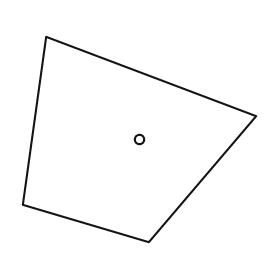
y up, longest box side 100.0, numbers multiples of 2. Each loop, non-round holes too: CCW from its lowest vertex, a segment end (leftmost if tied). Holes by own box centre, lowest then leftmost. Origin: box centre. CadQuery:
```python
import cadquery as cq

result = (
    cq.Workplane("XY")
    .moveTo(4.0, -44.0)
    .lineTo(50.0, 10.0)
    .lineTo(-40.0, 44.0)
    .lineTo(-50.0, -28.0)
    .close()
    .moveTo(0.0, 0.0)
    .circle(2.0)
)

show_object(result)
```